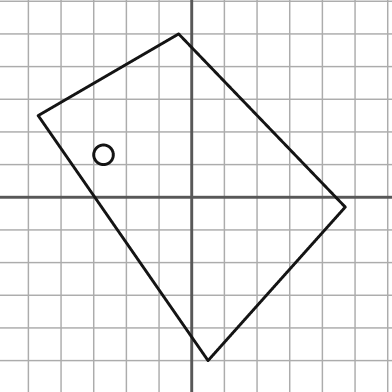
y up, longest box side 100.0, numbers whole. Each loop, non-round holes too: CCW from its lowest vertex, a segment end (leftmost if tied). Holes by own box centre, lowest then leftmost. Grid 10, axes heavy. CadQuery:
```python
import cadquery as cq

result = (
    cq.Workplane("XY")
    .moveTo(5.0, -50.0)
    .lineTo(47.0, -3.0)
    .lineTo(-4.0, 50.0)
    .lineTo(-47.0, 25.0)
    .close()
    .moveTo(-27.0, 13.0)
    .circle(3.0)
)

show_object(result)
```